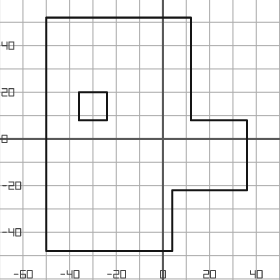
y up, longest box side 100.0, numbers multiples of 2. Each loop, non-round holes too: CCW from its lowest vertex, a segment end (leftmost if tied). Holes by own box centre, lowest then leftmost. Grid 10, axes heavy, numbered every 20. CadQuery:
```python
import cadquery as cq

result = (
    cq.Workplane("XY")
    .moveTo(-50.0, -48.0)
    .lineTo(4.0, -48.0)
    .lineTo(4.0, -22.0)
    .lineTo(36.0, -22.0)
    .lineTo(36.0, 8.0)
    .lineTo(12.0, 8.0)
    .lineTo(12.0, 52.0)
    .lineTo(-50.0, 52.0)
    .close()
    .moveTo(-36.0, 8.0)
    .lineTo(-24.0, 8.0)
    .lineTo(-24.0, 20.0)
    .lineTo(-36.0, 20.0)
    .close()
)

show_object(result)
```